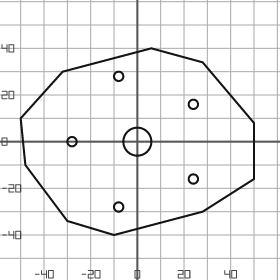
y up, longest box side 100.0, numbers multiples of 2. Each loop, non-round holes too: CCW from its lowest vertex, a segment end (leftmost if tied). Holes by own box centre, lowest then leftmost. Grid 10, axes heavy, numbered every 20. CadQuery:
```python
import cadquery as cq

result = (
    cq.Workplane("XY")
    .moveTo(-10.0, -40.0)
    .lineTo(28.0, -30.0)
    .lineTo(50.0, -16.0)
    .lineTo(50.0, 8.0)
    .lineTo(28.0, 34.0)
    .lineTo(6.0, 40.0)
    .lineTo(-32.0, 30.0)
    .lineTo(-50.0, 10.0)
    .lineTo(-48.0, -10.0)
    .lineTo(-30.0, -34.0)
    .close()
    .moveTo(-8.0, -28.0)
    .circle(2.0)
    .moveTo(24.0, -16.0)
    .circle(2.0)
    .moveTo(-28.0, 0.0)
    .circle(2.0)
    .moveTo(0.0, 0.0)
    .circle(6.0)
    .moveTo(24.0, 16.0)
    .circle(2.0)
    .moveTo(-8.0, 28.0)
    .circle(2.0)
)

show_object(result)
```